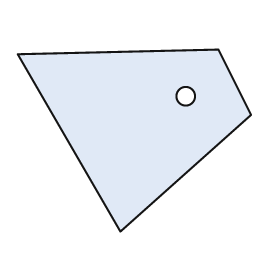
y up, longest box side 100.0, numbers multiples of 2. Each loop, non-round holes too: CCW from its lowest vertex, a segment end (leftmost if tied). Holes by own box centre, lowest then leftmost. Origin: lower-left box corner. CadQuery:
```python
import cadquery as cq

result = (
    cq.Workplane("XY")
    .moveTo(44.0, 0.0)
    .lineTo(100.0, 50.0)
    .lineTo(86.0, 78.0)
    .lineTo(0.0, 76.0)
    .close()
    .moveTo(72.0, 58.0)
    .circle(4.0)
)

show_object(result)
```